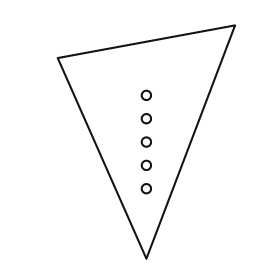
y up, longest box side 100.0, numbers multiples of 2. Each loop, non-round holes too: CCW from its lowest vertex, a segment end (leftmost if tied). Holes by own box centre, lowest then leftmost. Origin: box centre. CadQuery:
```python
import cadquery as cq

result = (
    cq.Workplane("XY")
    .moveTo(0.0, -50.0)
    .lineTo(38.0, 50.0)
    .lineTo(-38.0, 36.0)
    .close()
    .moveTo(0.0, -20.0)
    .circle(2.0)
    .moveTo(0.0, -10.0)
    .circle(2.0)
    .moveTo(0.0, 0.0)
    .circle(2.0)
    .moveTo(0.0, 10.0)
    .circle(2.0)
    .moveTo(0.0, 20.0)
    .circle(2.0)
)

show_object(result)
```